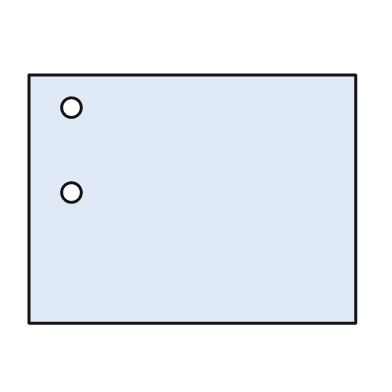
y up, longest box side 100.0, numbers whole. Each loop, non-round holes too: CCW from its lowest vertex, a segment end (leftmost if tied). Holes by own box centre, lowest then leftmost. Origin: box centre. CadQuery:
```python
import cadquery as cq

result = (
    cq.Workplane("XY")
    .moveTo(-50.0, -38.0)
    .lineTo(50.0, -38.0)
    .lineTo(50.0, 38.0)
    .lineTo(-50.0, 38.0)
    .close()
    .moveTo(-37.0, 2.0)
    .circle(3.0)
    .moveTo(-37.0, 28.0)
    .circle(3.0)
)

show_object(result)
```